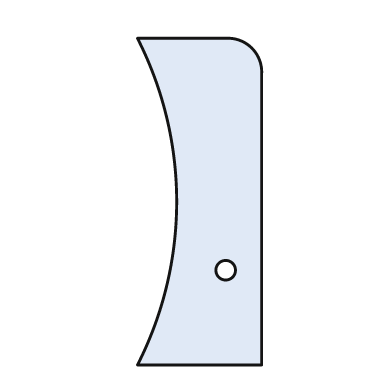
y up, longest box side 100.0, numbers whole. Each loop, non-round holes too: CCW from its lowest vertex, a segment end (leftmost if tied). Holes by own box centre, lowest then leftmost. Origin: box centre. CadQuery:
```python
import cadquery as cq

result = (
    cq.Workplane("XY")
    .moveTo(-19.0, -50.0)
    .lineTo(19.0, -50.0)
    .lineTo(19.0, 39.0)
    .threePointArc((16.0, 47.0), (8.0, 50.0))
    .lineTo(-19.0, 50.0)
    .threePointArc((-7.0, 0.0), (-19.0, -50.0))
    .close()
    .moveTo(8.0, -21.0)
    .circle(3.0)
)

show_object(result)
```